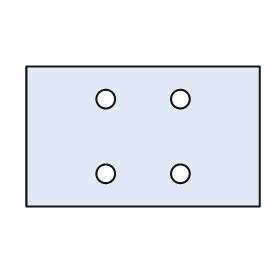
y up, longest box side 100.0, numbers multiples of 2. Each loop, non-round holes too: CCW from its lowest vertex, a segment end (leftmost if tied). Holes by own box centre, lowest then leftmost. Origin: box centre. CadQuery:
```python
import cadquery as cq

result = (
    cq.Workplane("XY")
    .moveTo(-50.0, -30.0)
    .lineTo(50.0, -30.0)
    .lineTo(50.0, 30.0)
    .lineTo(-50.0, 30.0)
    .close()
    .moveTo(-16.0, -16.0)
    .circle(4.0)
    .moveTo(16.0, -16.0)
    .circle(4.0)
    .moveTo(-16.0, 16.0)
    .circle(4.0)
    .moveTo(16.0, 16.0)
    .circle(4.0)
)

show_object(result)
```